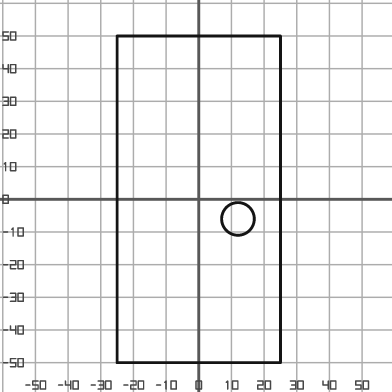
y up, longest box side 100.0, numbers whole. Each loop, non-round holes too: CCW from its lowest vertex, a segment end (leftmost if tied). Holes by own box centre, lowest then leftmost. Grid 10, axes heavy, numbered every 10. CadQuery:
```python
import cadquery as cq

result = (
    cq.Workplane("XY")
    .moveTo(-25.0, -50.0)
    .lineTo(25.0, -50.0)
    .lineTo(25.0, 50.0)
    .lineTo(-25.0, 50.0)
    .close()
    .moveTo(12.0, -6.0)
    .circle(5.0)
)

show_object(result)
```